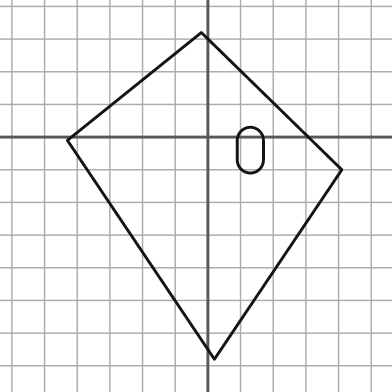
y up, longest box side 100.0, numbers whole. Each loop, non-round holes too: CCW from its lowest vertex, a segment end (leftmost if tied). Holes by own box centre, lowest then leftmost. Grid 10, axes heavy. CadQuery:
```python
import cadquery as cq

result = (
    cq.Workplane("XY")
    .moveTo(2.0, -68.0)
    .lineTo(41.0, -10.0)
    .lineTo(-2.0, 32.0)
    .lineTo(-43.0, -1.0)
    .close()
    .moveTo(9.0, -7.0)
    .threePointArc((13.0, -11.0), (17.0, -7.0))
    .lineTo(17.0, -1.0)
    .threePointArc((13.0, 3.0), (9.0, -1.0))
    .close()
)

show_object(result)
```